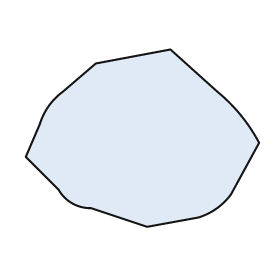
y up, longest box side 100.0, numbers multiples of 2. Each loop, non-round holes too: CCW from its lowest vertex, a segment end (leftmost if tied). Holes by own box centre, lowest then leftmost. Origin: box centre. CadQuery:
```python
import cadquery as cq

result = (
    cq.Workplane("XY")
    .moveTo(2.0, -38.0)
    .lineTo(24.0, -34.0)
    .threePointArc((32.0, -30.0), (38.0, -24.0))
    .lineTo(50.0, -2.0)
    .threePointArc((42.0, 10.0), (32.0, 20.0))
    .lineTo(12.0, 38.0)
    .lineTo(-20.0, 32.0)
    .lineTo(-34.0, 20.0)
    .threePointArc((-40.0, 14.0), (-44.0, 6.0))
    .lineTo(-50.0, -8.0)
    .lineTo(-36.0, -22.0)
    .threePointArc((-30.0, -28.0), (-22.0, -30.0))
    .close()
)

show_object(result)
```